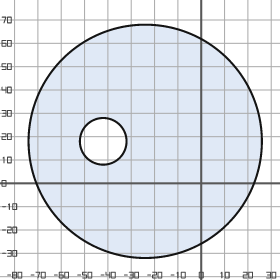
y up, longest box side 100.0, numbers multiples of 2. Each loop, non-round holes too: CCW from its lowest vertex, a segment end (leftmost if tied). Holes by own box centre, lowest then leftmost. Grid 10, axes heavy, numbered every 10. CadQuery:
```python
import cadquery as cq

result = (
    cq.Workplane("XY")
    .moveTo(-24.0, 18.0)
    .circle(50.0)
    .moveTo(-42.0, 18.0)
    .circle(10.0)
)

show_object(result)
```